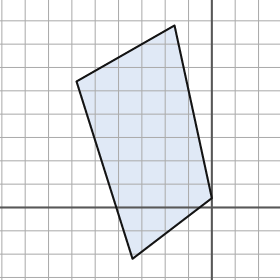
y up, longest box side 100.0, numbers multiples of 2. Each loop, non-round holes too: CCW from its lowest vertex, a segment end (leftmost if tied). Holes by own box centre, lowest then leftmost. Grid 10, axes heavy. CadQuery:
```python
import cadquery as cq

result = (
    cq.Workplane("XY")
    .moveTo(-34.0, -22.0)
    .lineTo(0.0, 4.0)
    .lineTo(-16.0, 78.0)
    .lineTo(-58.0, 54.0)
    .close()
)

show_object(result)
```